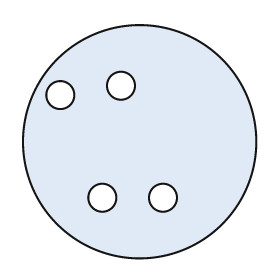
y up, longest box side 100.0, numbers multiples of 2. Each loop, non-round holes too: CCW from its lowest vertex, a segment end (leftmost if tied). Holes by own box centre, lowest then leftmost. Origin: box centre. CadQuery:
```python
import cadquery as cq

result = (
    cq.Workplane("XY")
    .moveTo(0.0, 0.0)
    .circle(50.0)
    .moveTo(-16.0, -24.0)
    .circle(6.0)
    .moveTo(10.0, -24.0)
    .circle(6.0)
    .moveTo(-34.0, 20.0)
    .circle(6.0)
    .moveTo(-8.0, 24.0)
    .circle(6.0)
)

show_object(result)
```